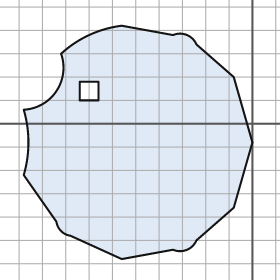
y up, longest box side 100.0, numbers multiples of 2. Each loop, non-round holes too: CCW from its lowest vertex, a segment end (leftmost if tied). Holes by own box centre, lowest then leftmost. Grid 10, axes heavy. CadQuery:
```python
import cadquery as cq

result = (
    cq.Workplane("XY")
    .moveTo(-56.0, -58.0)
    .lineTo(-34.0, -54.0)
    .threePointArc((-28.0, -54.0), (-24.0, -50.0))
    .lineTo(-8.0, -36.0)
    .lineTo(0.0, -8.0)
    .lineTo(-8.0, 20.0)
    .lineTo(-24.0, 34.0)
    .threePointArc((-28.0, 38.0), (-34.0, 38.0))
    .lineTo(-56.0, 42.0)
    .threePointArc((-70.0, 38.0), (-82.0, 30.0))
    .threePointArc((-84.0, 14.0), (-98.0, 6.0))
    .threePointArc((-96.0, -8.0), (-98.0, -22.0))
    .lineTo(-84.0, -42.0)
    .threePointArc((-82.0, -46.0), (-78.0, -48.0))
    .close()
    .moveTo(-74.0, 10.0)
    .lineTo(-66.0, 10.0)
    .lineTo(-66.0, 18.0)
    .lineTo(-74.0, 18.0)
    .close()
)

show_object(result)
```